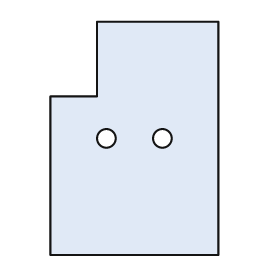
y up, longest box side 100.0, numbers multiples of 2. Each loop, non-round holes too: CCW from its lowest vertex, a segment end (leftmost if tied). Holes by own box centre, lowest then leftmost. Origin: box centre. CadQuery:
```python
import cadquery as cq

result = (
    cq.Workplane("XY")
    .moveTo(-36.0, -50.0)
    .lineTo(36.0, -50.0)
    .lineTo(36.0, 50.0)
    .lineTo(-16.0, 50.0)
    .lineTo(-16.0, 18.0)
    .lineTo(-36.0, 18.0)
    .close()
    .moveTo(-12.0, 0.0)
    .circle(4.0)
    .moveTo(12.0, 0.0)
    .circle(4.0)
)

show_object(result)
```